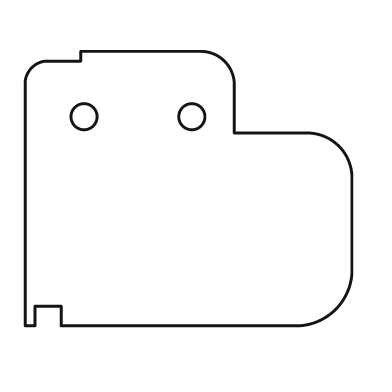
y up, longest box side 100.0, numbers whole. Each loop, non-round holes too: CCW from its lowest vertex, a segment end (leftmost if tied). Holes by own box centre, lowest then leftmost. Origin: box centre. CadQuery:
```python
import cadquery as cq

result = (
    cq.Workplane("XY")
    .moveTo(-50.0, -42.0)
    .lineTo(-47.0, -42.0)
    .lineTo(-47.0, -36.0)
    .lineTo(-39.0, -36.0)
    .lineTo(-39.0, -42.0)
    .lineTo(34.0, -42.0)
    .threePointArc((45.0, -37.0), (50.0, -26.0))
    .lineTo(50.0, 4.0)
    .threePointArc((46.0, 13.0), (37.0, 17.0))
    .lineTo(14.0, 17.0)
    .lineTo(14.0, 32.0)
    .threePointArc((11.0, 39.0), (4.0, 42.0))
    .lineTo(-33.0, 42.0)
    .lineTo(-33.0, 39.0)
    .lineTo(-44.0, 39.0)
    .threePointArc((-48.0, 37.0), (-50.0, 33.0))
    .close()
    .moveTo(-32.0, 22.0)
    .circle(4.0)
    .moveTo(1.0, 22.0)
    .circle(4.0)
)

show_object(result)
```